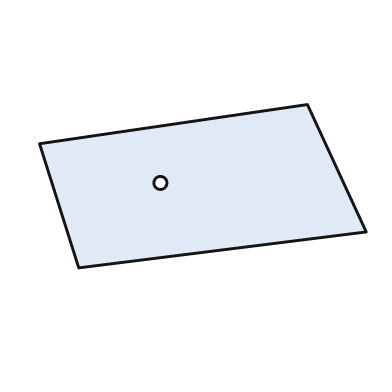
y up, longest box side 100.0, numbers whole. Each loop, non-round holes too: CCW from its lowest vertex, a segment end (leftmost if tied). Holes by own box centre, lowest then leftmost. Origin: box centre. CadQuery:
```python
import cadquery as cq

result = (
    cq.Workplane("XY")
    .moveTo(-38.0, -25.0)
    .lineTo(50.0, -14.0)
    .lineTo(32.0, 25.0)
    .lineTo(-50.0, 13.0)
    .close()
    .moveTo(-13.0, 1.0)
    .circle(2.0)
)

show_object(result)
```